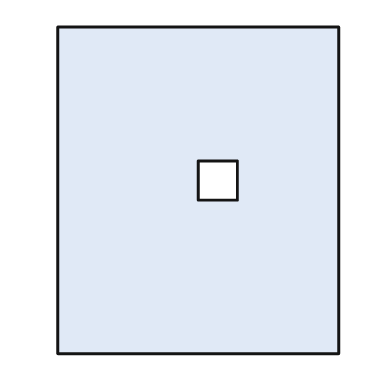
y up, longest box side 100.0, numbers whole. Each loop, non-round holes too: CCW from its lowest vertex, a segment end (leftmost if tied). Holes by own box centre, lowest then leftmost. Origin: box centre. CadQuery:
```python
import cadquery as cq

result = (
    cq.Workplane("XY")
    .moveTo(-43.0, -50.0)
    .lineTo(43.0, -50.0)
    .lineTo(43.0, 50.0)
    .lineTo(-43.0, 50.0)
    .close()
    .moveTo(0.0, -3.0)
    .lineTo(12.0, -3.0)
    .lineTo(12.0, 9.0)
    .lineTo(0.0, 9.0)
    .close()
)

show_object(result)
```